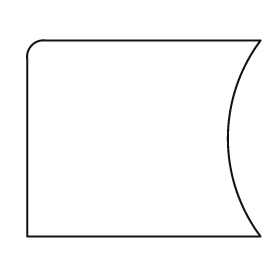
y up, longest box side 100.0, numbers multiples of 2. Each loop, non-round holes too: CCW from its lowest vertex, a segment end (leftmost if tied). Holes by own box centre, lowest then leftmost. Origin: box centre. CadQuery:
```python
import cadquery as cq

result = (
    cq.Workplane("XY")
    .moveTo(-50.0, -42.0)
    .lineTo(50.0, -42.0)
    .threePointArc((36.0, 0.0), (50.0, 42.0))
    .lineTo(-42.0, 42.0)
    .threePointArc((-48.0, 40.0), (-50.0, 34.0))
    .close()
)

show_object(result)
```